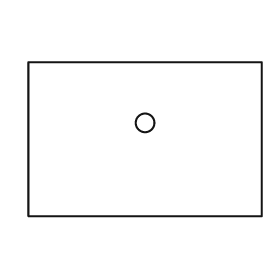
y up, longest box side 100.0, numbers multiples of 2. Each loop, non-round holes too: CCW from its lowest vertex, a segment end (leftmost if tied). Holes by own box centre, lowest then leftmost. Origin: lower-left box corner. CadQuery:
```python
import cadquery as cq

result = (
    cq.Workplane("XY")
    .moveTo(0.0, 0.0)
    .lineTo(100.0, 0.0)
    .lineTo(100.0, 66.0)
    .lineTo(0.0, 66.0)
    .close()
    .moveTo(50.0, 40.0)
    .circle(4.0)
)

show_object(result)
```